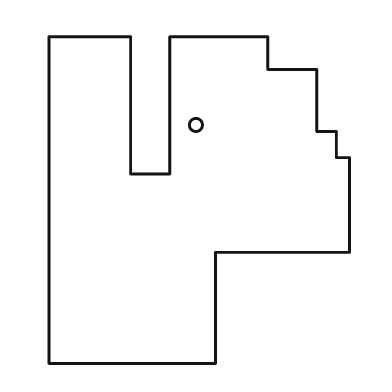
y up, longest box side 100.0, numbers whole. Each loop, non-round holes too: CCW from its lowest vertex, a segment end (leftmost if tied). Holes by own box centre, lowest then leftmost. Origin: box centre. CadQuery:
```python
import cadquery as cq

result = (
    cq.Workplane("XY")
    .moveTo(-46.0, -50.0)
    .lineTo(5.0, -50.0)
    .lineTo(5.0, -16.0)
    .lineTo(46.0, -16.0)
    .lineTo(46.0, 13.0)
    .lineTo(42.0, 13.0)
    .lineTo(42.0, 21.0)
    .lineTo(36.0, 21.0)
    .lineTo(36.0, 40.0)
    .lineTo(21.0, 40.0)
    .lineTo(21.0, 50.0)
    .lineTo(-9.0, 50.0)
    .lineTo(-9.0, 8.0)
    .lineTo(-21.0, 8.0)
    .lineTo(-21.0, 50.0)
    .lineTo(-46.0, 50.0)
    .close()
    .moveTo(-1.0, 23.0)
    .circle(2.0)
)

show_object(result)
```